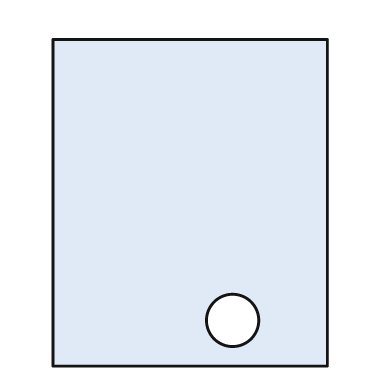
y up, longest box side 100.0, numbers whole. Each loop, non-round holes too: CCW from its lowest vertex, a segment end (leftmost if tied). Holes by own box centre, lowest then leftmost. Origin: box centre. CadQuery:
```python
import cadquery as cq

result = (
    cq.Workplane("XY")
    .moveTo(-42.0, -50.0)
    .lineTo(42.0, -50.0)
    .lineTo(42.0, 50.0)
    .lineTo(-42.0, 50.0)
    .close()
    .moveTo(13.0, -36.0)
    .circle(8.0)
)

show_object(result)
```